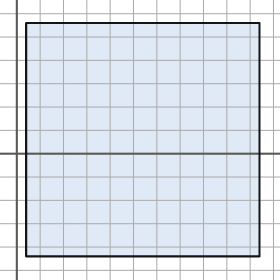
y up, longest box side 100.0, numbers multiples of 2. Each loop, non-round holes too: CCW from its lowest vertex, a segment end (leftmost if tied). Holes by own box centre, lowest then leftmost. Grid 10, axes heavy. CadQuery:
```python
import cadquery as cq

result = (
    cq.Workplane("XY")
    .moveTo(4.0, -44.0)
    .lineTo(104.0, -44.0)
    .lineTo(104.0, 56.0)
    .lineTo(4.0, 56.0)
    .close()
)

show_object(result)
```